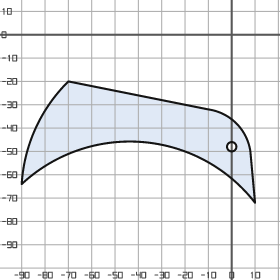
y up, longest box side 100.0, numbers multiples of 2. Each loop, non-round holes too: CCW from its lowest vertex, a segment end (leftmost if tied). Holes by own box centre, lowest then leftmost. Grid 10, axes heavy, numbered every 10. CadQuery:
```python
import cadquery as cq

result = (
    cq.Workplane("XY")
    .moveTo(10.0, -72.0)
    .lineTo(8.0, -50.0)
    .threePointArc((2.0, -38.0), (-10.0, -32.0))
    .lineTo(-70.0, -20.0)
    .threePointArc((-84.0, -40.0), (-90.0, -64.0))
    .threePointArc((-38.0, -46.0), (10.0, -72.0))
    .close()
    .moveTo(0.0, -48.0)
    .circle(2.0)
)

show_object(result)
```